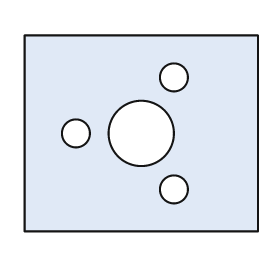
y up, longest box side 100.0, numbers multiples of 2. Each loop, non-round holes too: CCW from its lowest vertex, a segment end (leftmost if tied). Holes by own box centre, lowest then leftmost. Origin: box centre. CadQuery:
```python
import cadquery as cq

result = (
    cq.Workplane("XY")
    .moveTo(-50.0, -42.0)
    .lineTo(50.0, -42.0)
    .lineTo(50.0, 42.0)
    .lineTo(-50.0, 42.0)
    .close()
    .moveTo(14.0, -24.0)
    .circle(6.0)
    .moveTo(-28.0, 0.0)
    .circle(6.0)
    .moveTo(0.0, 0.0)
    .circle(14.0)
    .moveTo(14.0, 24.0)
    .circle(6.0)
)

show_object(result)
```